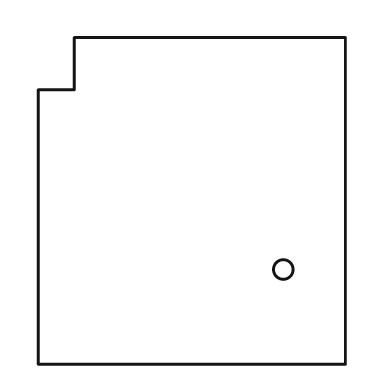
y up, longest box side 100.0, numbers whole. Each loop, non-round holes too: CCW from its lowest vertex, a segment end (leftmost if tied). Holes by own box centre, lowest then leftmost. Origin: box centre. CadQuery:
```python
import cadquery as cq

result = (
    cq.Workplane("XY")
    .moveTo(-47.0, -50.0)
    .lineTo(47.0, -50.0)
    .lineTo(47.0, 50.0)
    .lineTo(-36.0, 50.0)
    .lineTo(-36.0, 34.0)
    .lineTo(-47.0, 34.0)
    .close()
    .moveTo(28.0, -21.0)
    .circle(3.0)
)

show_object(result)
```